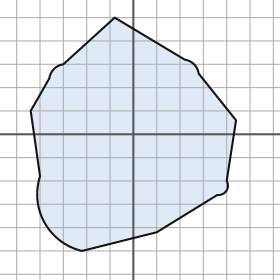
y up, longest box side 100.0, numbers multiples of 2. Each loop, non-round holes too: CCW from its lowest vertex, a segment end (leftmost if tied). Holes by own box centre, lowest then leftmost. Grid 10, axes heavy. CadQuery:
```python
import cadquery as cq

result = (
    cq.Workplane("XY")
    .moveTo(-22.0, -50.0)
    .lineTo(10.0, -42.0)
    .lineTo(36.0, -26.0)
    .threePointArc((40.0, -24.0), (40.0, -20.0))
    .lineTo(44.0, 6.0)
    .lineTo(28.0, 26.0)
    .threePointArc((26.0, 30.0), (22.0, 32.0))
    .lineTo(-8.0, 50.0)
    .lineTo(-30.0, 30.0)
    .threePointArc((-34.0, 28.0), (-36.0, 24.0))
    .lineTo(-44.0, 10.0)
    .lineTo(-40.0, -18.0)
    .threePointArc((-38.0, -38.0), (-22.0, -50.0))
    .close()
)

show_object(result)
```